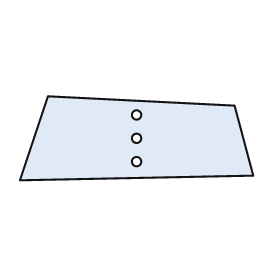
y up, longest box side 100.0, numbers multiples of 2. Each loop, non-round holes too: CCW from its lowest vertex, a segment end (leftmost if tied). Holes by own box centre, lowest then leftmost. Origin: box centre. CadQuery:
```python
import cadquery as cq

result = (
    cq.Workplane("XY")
    .moveTo(-50.0, -18.0)
    .lineTo(50.0, -16.0)
    .lineTo(42.0, 14.0)
    .lineTo(-38.0, 18.0)
    .close()
    .moveTo(0.0, -10.0)
    .circle(2.0)
    .moveTo(0.0, 0.0)
    .circle(2.0)
    .moveTo(0.0, 10.0)
    .circle(2.0)
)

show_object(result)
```